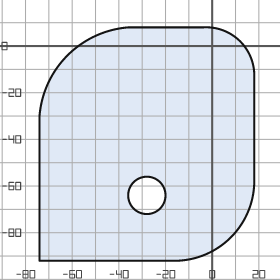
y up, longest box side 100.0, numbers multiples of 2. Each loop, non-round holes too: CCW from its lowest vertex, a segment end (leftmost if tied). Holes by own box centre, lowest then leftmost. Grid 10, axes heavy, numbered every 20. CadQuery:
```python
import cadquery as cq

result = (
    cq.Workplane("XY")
    .moveTo(-74.0, -92.0)
    .lineTo(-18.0, -92.0)
    .threePointArc((8.0, -82.0), (18.0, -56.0))
    .lineTo(18.0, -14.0)
    .threePointArc((12.0, 2.0), (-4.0, 8.0))
    .lineTo(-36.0, 8.0)
    .threePointArc((-62.0, -4.0), (-74.0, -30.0))
    .close()
    .moveTo(-28.0, -64.0)
    .circle(8.0)
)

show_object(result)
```